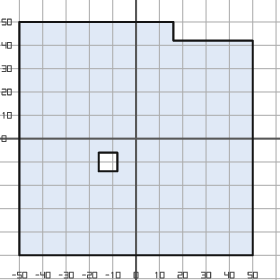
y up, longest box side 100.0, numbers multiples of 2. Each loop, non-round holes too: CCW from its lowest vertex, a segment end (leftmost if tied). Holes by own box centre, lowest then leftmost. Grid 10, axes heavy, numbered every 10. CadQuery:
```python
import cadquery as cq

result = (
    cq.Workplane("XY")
    .moveTo(-50.0, -50.0)
    .lineTo(50.0, -50.0)
    .lineTo(50.0, 42.0)
    .lineTo(16.0, 42.0)
    .lineTo(16.0, 50.0)
    .lineTo(-50.0, 50.0)
    .close()
    .moveTo(-16.0, -14.0)
    .lineTo(-8.0, -14.0)
    .lineTo(-8.0, -6.0)
    .lineTo(-16.0, -6.0)
    .close()
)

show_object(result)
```